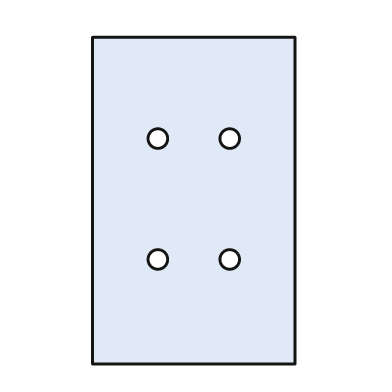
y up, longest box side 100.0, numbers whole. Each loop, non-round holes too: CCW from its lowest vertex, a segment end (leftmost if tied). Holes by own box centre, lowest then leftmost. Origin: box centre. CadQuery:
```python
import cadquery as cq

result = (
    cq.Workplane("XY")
    .moveTo(-31.0, -50.0)
    .lineTo(31.0, -50.0)
    .lineTo(31.0, 50.0)
    .lineTo(-31.0, 50.0)
    .close()
    .moveTo(-11.0, -18.0)
    .circle(3.0)
    .moveTo(11.0, -18.0)
    .circle(3.0)
    .moveTo(-11.0, 19.0)
    .circle(3.0)
    .moveTo(11.0, 19.0)
    .circle(3.0)
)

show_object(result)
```